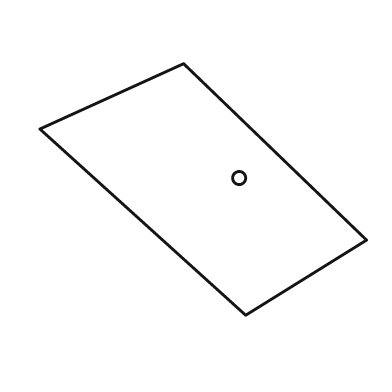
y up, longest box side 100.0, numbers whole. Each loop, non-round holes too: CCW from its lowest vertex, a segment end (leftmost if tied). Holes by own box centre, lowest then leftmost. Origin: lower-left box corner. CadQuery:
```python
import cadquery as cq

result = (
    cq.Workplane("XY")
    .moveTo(63.0, 0.0)
    .lineTo(100.0, 23.0)
    .lineTo(44.0, 77.0)
    .lineTo(0.0, 57.0)
    .close()
    .moveTo(61.0, 42.0)
    .circle(2.0)
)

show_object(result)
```